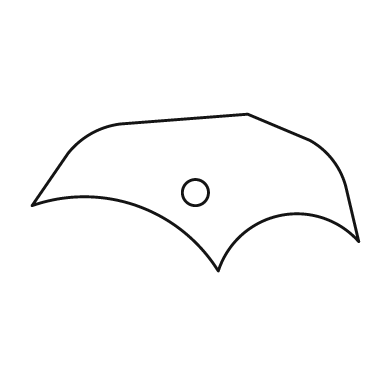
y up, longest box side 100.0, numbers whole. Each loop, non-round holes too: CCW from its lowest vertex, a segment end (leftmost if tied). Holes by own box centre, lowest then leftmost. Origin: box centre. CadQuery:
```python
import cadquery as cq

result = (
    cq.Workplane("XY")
    .moveTo(7.0, -24.0)
    .threePointArc((26.0, -7.0), (50.0, -15.0))
    .lineTo(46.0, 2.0)
    .threePointArc((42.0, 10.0), (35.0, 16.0))
    .lineTo(16.0, 24.0)
    .lineTo(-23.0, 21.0)
    .threePointArc((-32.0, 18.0), (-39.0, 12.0))
    .lineTo(-50.0, -4.0)
    .threePointArc((-18.0, -4.0), (7.0, -24.0))
    .close()
    .moveTo(0.0, 0.0)
    .circle(4.0)
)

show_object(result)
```